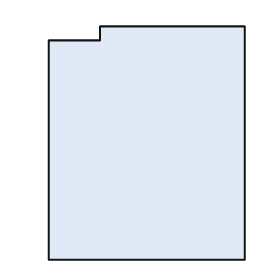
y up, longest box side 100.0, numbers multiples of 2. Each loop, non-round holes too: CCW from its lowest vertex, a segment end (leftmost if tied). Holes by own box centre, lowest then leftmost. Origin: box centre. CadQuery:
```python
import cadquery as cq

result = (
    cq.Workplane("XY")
    .moveTo(-42.0, -50.0)
    .lineTo(42.0, -50.0)
    .lineTo(42.0, 50.0)
    .lineTo(-20.0, 50.0)
    .lineTo(-20.0, 44.0)
    .lineTo(-42.0, 44.0)
    .close()
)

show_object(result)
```